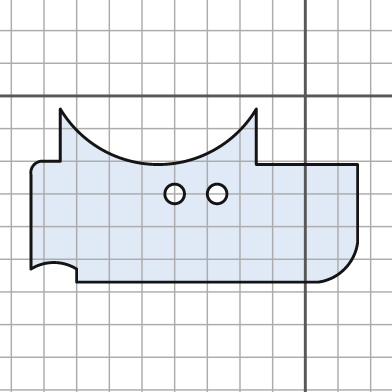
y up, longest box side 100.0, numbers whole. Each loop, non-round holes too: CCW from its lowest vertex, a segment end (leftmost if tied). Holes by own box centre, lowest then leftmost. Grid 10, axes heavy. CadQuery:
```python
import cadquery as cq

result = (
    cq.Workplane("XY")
    .moveTo(-70.0, -57.0)
    .lineTo(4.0, -57.0)
    .threePointArc((12.0, -53.0), (16.0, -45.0))
    .lineTo(16.0, -21.0)
    .lineTo(-15.0, -21.0)
    .lineTo(-15.0, -4.0)
    .threePointArc((-45.0, -21.0), (-75.0, -4.0))
    .lineTo(-75.0, -20.0)
    .lineTo(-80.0, -20.0)
    .threePointArc((-83.0, -21.0), (-84.0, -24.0))
    .lineTo(-84.0, -53.0)
    .threePointArc((-77.0, -51.0), (-70.0, -53.0))
    .close()
    .moveTo(-40.0, -30.0)
    .circle(3.0)
    .moveTo(-27.0, -30.0)
    .circle(3.0)
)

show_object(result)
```